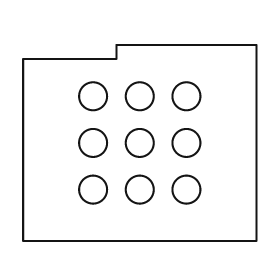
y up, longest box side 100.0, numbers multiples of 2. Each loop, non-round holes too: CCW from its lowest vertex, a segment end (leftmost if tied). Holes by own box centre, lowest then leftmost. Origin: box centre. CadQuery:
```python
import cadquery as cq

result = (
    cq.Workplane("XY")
    .moveTo(-50.0, -42.0)
    .lineTo(50.0, -42.0)
    .lineTo(50.0, 42.0)
    .lineTo(-10.0, 42.0)
    .lineTo(-10.0, 36.0)
    .lineTo(-50.0, 36.0)
    .close()
    .moveTo(-20.0, -20.0)
    .circle(6.0)
    .moveTo(0.0, -20.0)
    .circle(6.0)
    .moveTo(20.0, -20.0)
    .circle(6.0)
    .moveTo(-20.0, 0.0)
    .circle(6.0)
    .moveTo(0.0, 0.0)
    .circle(6.0)
    .moveTo(20.0, 0.0)
    .circle(6.0)
    .moveTo(-20.0, 20.0)
    .circle(6.0)
    .moveTo(0.0, 20.0)
    .circle(6.0)
    .moveTo(20.0, 20.0)
    .circle(6.0)
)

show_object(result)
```